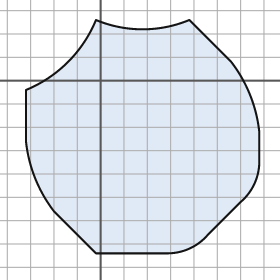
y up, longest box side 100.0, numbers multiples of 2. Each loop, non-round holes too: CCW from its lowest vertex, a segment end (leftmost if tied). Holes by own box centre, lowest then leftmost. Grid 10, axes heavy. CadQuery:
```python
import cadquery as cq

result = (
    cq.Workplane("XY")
    .moveTo(-2.0, -74.0)
    .lineTo(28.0, -74.0)
    .threePointArc((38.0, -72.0), (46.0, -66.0))
    .lineTo(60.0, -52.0)
    .threePointArc((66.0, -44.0), (68.0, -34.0))
    .lineTo(68.0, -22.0)
    .threePointArc((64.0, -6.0), (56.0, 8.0))
    .lineTo(38.0, 26.0)
    .threePointArc((18.0, 22.0), (-2.0, 26.0))
    .threePointArc((-14.0, 8.0), (-32.0, -4.0))
    .lineTo(-32.0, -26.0)
    .threePointArc((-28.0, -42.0), (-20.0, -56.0))
    .close()
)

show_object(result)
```